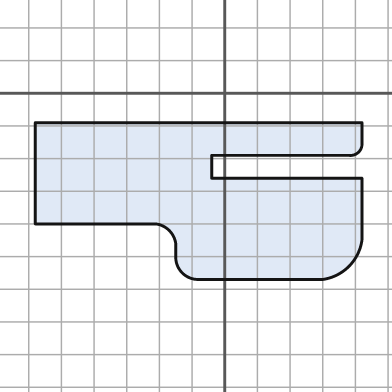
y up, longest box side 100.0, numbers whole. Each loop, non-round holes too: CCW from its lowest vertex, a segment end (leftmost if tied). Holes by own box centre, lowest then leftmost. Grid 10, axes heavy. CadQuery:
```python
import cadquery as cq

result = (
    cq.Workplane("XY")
    .moveTo(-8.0, -57.0)
    .lineTo(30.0, -57.0)
    .threePointArc((38.0, -53.0), (42.0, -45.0))
    .lineTo(42.0, -26.0)
    .lineTo(-4.0, -26.0)
    .lineTo(-4.0, -19.0)
    .lineTo(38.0, -19.0)
    .threePointArc((41.0, -18.0), (42.0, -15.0))
    .lineTo(42.0, -9.0)
    .lineTo(-58.0, -9.0)
    .lineTo(-58.0, -40.0)
    .lineTo(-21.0, -40.0)
    .threePointArc((-17.0, -42.0), (-15.0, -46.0))
    .lineTo(-15.0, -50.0)
    .threePointArc((-13.0, -55.0), (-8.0, -57.0))
    .close()
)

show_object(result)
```